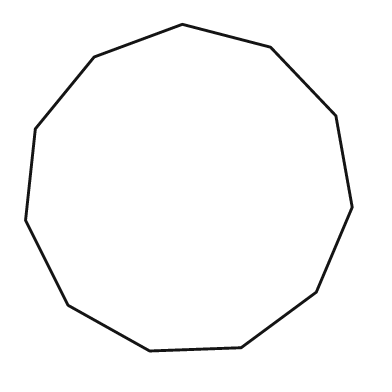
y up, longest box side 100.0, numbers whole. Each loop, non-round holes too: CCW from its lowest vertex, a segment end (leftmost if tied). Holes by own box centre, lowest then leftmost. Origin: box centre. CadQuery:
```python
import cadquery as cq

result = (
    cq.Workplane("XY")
    .moveTo(-12.0, -50.0)
    .lineTo(16.0, -49.0)
    .lineTo(39.0, -32.0)
    .lineTo(50.0, -6.0)
    .lineTo(45.0, 22.0)
    .lineTo(25.0, 43.0)
    .lineTo(-2.0, 50.0)
    .lineTo(-29.0, 40.0)
    .lineTo(-47.0, 18.0)
    .lineTo(-50.0, -10.0)
    .lineTo(-37.0, -36.0)
    .close()
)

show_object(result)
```